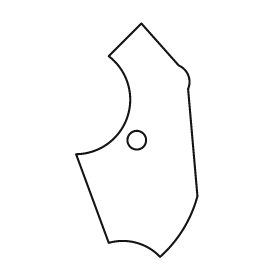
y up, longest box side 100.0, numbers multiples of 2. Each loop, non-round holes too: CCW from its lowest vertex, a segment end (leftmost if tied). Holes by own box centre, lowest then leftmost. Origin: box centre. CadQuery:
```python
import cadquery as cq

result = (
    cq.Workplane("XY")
    .moveTo(10.0, -50.0)
    .threePointArc((20.0, -38.0), (26.0, -24.0))
    .lineTo(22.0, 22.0)
    .threePointArc((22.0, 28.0), (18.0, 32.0))
    .lineTo(2.0, 50.0)
    .lineTo(-12.0, 36.0)
    .threePointArc((-4.0, 10.0), (-26.0, -6.0))
    .lineTo(-12.0, -44.0)
    .threePointArc((0.0, -44.0), (10.0, -50.0))
    .close()
    .moveTo(0.0, 0.0)
    .circle(4.0)
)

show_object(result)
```